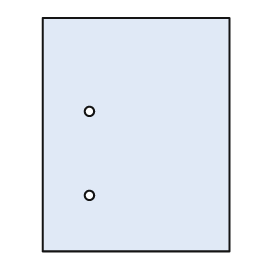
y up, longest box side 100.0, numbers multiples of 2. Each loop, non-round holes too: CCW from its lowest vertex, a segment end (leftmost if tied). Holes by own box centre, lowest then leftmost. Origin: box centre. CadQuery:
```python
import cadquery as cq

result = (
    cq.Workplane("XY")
    .moveTo(-40.0, -50.0)
    .lineTo(40.0, -50.0)
    .lineTo(40.0, 50.0)
    .lineTo(-40.0, 50.0)
    .close()
    .moveTo(-20.0, -26.0)
    .circle(2.0)
    .moveTo(-20.0, 10.0)
    .circle(2.0)
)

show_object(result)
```